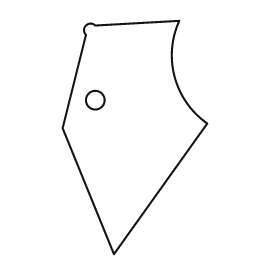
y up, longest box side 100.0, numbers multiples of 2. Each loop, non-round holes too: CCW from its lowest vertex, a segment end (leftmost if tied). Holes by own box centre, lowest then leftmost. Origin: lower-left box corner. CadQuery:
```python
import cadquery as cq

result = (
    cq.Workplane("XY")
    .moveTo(22.0, 0.0)
    .lineTo(62.0, 56.0)
    .threePointArc((48.0, 76.0), (50.0, 100.0))
    .lineTo(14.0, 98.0)
    .threePointArc((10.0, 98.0), (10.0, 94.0))
    .lineTo(0.0, 54.0)
    .close()
    .moveTo(14.0, 66.0)
    .circle(4.0)
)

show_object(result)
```